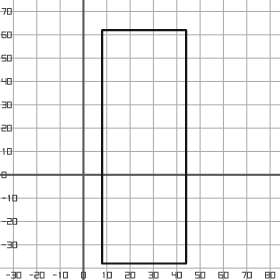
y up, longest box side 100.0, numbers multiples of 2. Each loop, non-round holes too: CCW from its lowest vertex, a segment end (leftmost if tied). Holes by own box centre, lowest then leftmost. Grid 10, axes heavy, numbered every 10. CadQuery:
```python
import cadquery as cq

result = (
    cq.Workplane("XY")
    .moveTo(8.0, -38.0)
    .lineTo(44.0, -38.0)
    .lineTo(44.0, 62.0)
    .lineTo(8.0, 62.0)
    .close()
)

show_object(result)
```